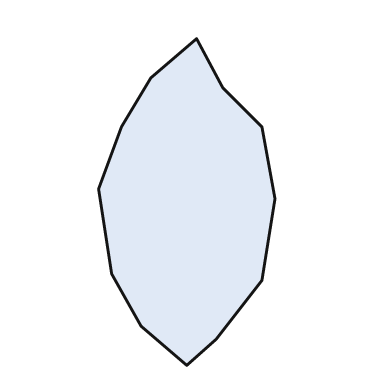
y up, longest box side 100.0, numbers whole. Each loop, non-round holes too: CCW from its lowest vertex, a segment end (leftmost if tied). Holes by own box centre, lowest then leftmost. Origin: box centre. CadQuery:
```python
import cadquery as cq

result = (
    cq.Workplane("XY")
    .moveTo(0.0, -50.0)
    .lineTo(9.0, -42.0)
    .lineTo(23.0, -24.0)
    .lineTo(27.0, 1.0)
    .lineTo(23.0, 23.0)
    .lineTo(11.0, 35.0)
    .lineTo(3.0, 50.0)
    .lineTo(-11.0, 38.0)
    .lineTo(-20.0, 23.0)
    .lineTo(-27.0, 4.0)
    .lineTo(-23.0, -22.0)
    .lineTo(-14.0, -38.0)
    .close()
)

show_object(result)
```